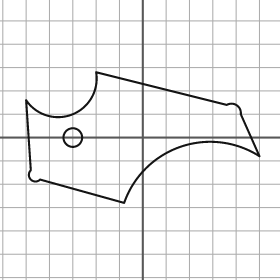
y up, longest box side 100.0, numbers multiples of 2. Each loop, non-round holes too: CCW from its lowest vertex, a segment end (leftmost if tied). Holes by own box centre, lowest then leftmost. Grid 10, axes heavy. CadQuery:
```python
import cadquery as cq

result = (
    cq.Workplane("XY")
    .moveTo(-8.0, -28.0)
    .threePointArc((16.0, -4.0), (50.0, -8.0))
    .lineTo(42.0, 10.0)
    .threePointArc((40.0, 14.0), (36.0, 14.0))
    .lineTo(-20.0, 28.0)
    .threePointArc((-30.0, 10.0), (-50.0, 16.0))
    .lineTo(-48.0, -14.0)
    .threePointArc((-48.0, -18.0), (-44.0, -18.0))
    .close()
    .moveTo(-30.0, 0.0)
    .circle(4.0)
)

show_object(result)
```